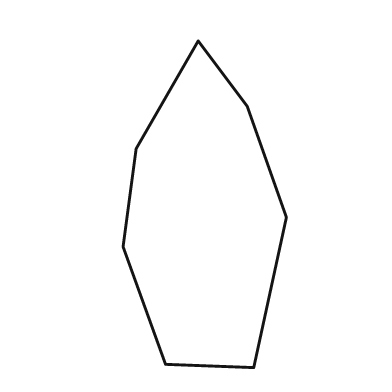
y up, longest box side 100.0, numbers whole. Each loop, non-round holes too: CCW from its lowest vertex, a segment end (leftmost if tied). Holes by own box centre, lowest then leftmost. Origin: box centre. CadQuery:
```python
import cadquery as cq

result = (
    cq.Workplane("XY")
    .moveTo(15.0, -50.0)
    .lineTo(25.0, -4.0)
    .lineTo(13.0, 30.0)
    .lineTo(-2.0, 50.0)
    .lineTo(-21.0, 17.0)
    .lineTo(-25.0, -13.0)
    .lineTo(-12.0, -49.0)
    .close()
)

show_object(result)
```